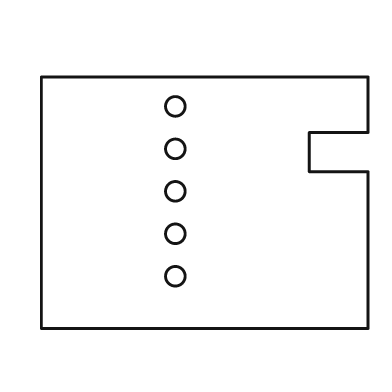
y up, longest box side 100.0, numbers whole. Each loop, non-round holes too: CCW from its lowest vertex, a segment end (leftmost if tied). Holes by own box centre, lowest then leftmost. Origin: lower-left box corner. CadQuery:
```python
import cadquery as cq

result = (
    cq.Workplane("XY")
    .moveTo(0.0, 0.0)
    .lineTo(100.0, 0.0)
    .lineTo(100.0, 48.0)
    .lineTo(82.0, 48.0)
    .lineTo(82.0, 60.0)
    .lineTo(100.0, 60.0)
    .lineTo(100.0, 77.0)
    .lineTo(0.0, 77.0)
    .close()
    .moveTo(41.0, 16.0)
    .circle(3.0)
    .moveTo(41.0, 29.0)
    .circle(3.0)
    .moveTo(41.0, 42.0)
    .circle(3.0)
    .moveTo(41.0, 55.0)
    .circle(3.0)
    .moveTo(41.0, 68.0)
    .circle(3.0)
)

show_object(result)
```